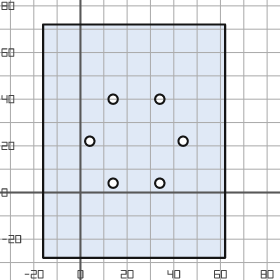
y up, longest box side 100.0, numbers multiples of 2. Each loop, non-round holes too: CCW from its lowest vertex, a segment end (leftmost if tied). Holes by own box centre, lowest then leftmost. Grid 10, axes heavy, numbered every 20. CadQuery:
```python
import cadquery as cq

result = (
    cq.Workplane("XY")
    .moveTo(-16.0, -28.0)
    .lineTo(62.0, -28.0)
    .lineTo(62.0, 72.0)
    .lineTo(-16.0, 72.0)
    .close()
    .moveTo(14.0, 4.0)
    .circle(2.0)
    .moveTo(34.0, 4.0)
    .circle(2.0)
    .moveTo(4.0, 22.0)
    .circle(2.0)
    .moveTo(44.0, 22.0)
    .circle(2.0)
    .moveTo(14.0, 40.0)
    .circle(2.0)
    .moveTo(34.0, 40.0)
    .circle(2.0)
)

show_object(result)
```